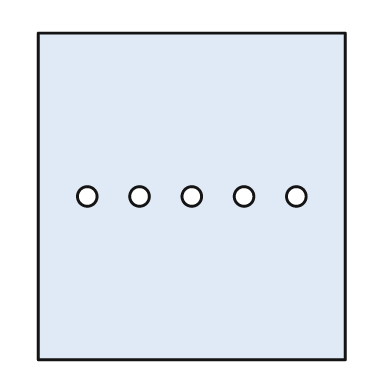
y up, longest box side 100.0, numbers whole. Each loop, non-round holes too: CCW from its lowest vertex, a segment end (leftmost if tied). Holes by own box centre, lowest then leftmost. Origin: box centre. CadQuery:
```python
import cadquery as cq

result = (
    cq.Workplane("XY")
    .moveTo(-47.0, -50.0)
    .lineTo(47.0, -50.0)
    .lineTo(47.0, 50.0)
    .lineTo(-47.0, 50.0)
    .close()
    .moveTo(-32.0, 0.0)
    .circle(3.0)
    .moveTo(-16.0, 0.0)
    .circle(3.0)
    .moveTo(0.0, 0.0)
    .circle(3.0)
    .moveTo(16.0, 0.0)
    .circle(3.0)
    .moveTo(32.0, 0.0)
    .circle(3.0)
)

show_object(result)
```